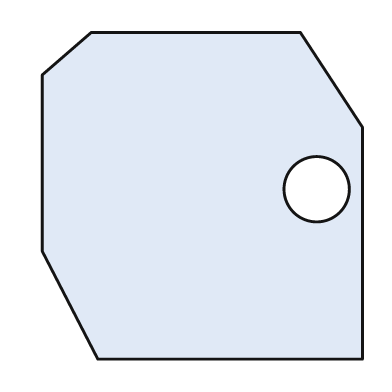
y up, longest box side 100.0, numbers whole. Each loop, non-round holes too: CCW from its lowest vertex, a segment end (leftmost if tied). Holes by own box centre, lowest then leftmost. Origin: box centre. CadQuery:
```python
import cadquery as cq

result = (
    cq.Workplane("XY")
    .moveTo(-32.0, -50.0)
    .lineTo(49.0, -50.0)
    .lineTo(49.0, 21.0)
    .lineTo(30.0, 50.0)
    .lineTo(-34.0, 50.0)
    .lineTo(-49.0, 37.0)
    .lineTo(-49.0, -17.0)
    .close()
    .moveTo(35.0, 2.0)
    .circle(10.0)
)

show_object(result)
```